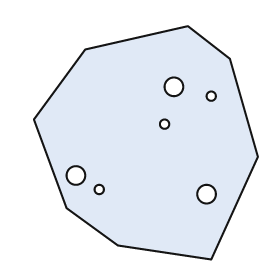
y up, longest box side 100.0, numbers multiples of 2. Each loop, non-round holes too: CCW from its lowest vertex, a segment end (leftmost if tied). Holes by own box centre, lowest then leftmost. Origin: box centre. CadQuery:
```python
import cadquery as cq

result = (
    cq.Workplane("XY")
    .moveTo(28.0, -50.0)
    .lineTo(48.0, -6.0)
    .lineTo(36.0, 36.0)
    .lineTo(18.0, 50.0)
    .lineTo(-26.0, 40.0)
    .lineTo(-48.0, 10.0)
    .lineTo(-34.0, -28.0)
    .lineTo(-12.0, -44.0)
    .close()
    .moveTo(26.0, -22.0)
    .circle(4.0)
    .moveTo(-20.0, -20.0)
    .circle(2.0)
    .moveTo(-30.0, -14.0)
    .circle(4.0)
    .moveTo(8.0, 8.0)
    .circle(2.0)
    .moveTo(28.0, 20.0)
    .circle(2.0)
    .moveTo(12.0, 24.0)
    .circle(4.0)
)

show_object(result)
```